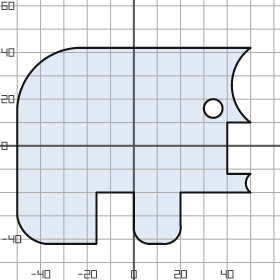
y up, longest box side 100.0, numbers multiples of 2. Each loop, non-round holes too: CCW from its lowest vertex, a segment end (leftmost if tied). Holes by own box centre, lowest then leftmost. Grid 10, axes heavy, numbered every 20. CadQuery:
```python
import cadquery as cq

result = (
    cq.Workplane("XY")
    .moveTo(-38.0, -42.0)
    .lineTo(-16.0, -42.0)
    .lineTo(-16.0, -20.0)
    .lineTo(0.0, -20.0)
    .lineTo(0.0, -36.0)
    .threePointArc((2.0, -40.0), (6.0, -42.0))
    .lineTo(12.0, -42.0)
    .threePointArc((18.0, -40.0), (20.0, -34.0))
    .lineTo(20.0, -20.0)
    .lineTo(50.0, -20.0)
    .threePointArc((48.0, -16.0), (50.0, -12.0))
    .lineTo(40.0, -12.0)
    .lineTo(40.0, 10.0)
    .lineTo(50.0, 10.0)
    .threePointArc((42.0, 26.0), (50.0, 42.0))
    .lineTo(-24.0, 42.0)
    .threePointArc((-42.0, 34.0), (-50.0, 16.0))
    .lineTo(-50.0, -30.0)
    .threePointArc((-46.0, -38.0), (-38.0, -42.0))
    .close()
    .moveTo(34.0, 16.0)
    .circle(4.0)
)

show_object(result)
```